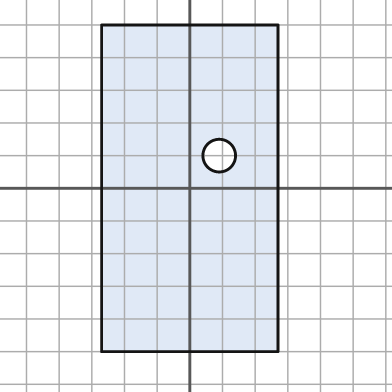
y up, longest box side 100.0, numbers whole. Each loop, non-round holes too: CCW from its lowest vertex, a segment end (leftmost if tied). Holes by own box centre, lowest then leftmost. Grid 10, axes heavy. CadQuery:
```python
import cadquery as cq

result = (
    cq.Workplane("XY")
    .moveTo(-27.0, -50.0)
    .lineTo(27.0, -50.0)
    .lineTo(27.0, 50.0)
    .lineTo(-27.0, 50.0)
    .close()
    .moveTo(9.0, 10.0)
    .circle(5.0)
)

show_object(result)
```